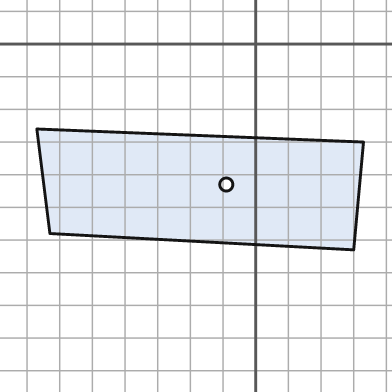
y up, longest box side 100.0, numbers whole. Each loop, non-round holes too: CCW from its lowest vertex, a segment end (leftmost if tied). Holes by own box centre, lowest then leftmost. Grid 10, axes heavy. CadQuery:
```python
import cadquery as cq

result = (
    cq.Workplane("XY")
    .moveTo(30.0, -63.0)
    .lineTo(33.0, -30.0)
    .lineTo(-67.0, -26.0)
    .lineTo(-63.0, -58.0)
    .close()
    .moveTo(-9.0, -43.0)
    .circle(2.0)
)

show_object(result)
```